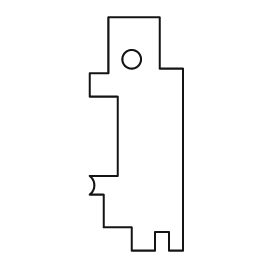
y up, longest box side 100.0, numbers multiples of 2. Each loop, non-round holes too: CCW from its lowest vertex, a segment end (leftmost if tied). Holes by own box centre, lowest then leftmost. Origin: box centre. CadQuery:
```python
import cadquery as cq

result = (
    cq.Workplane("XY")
    .moveTo(-2.0, -50.0)
    .lineTo(8.0, -50.0)
    .lineTo(8.0, -42.0)
    .lineTo(14.0, -42.0)
    .lineTo(14.0, -50.0)
    .lineTo(20.0, -50.0)
    .lineTo(20.0, 28.0)
    .lineTo(10.0, 28.0)
    .lineTo(10.0, 50.0)
    .lineTo(-12.0, 50.0)
    .lineTo(-12.0, 26.0)
    .lineTo(-20.0, 26.0)
    .lineTo(-20.0, 16.0)
    .lineTo(-8.0, 16.0)
    .lineTo(-8.0, -18.0)
    .lineTo(-20.0, -18.0)
    .threePointArc((-18.0, -22.0), (-20.0, -26.0))
    .lineTo(-14.0, -26.0)
    .lineTo(-14.0, -40.0)
    .lineTo(-2.0, -40.0)
    .close()
    .moveTo(-2.0, 32.0)
    .circle(4.0)
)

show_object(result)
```